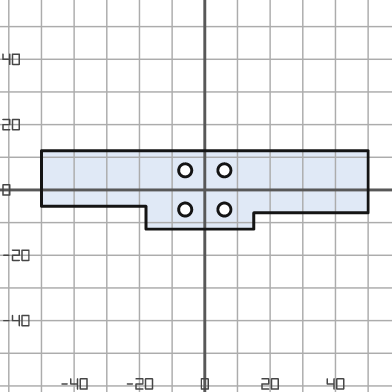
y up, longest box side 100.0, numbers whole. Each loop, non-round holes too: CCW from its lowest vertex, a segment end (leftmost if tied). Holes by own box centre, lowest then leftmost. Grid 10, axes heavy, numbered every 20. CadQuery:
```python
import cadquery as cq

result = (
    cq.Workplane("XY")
    .moveTo(-18.0, -12.0)
    .lineTo(15.0, -12.0)
    .lineTo(15.0, -7.0)
    .lineTo(50.0, -7.0)
    .lineTo(50.0, 12.0)
    .lineTo(-50.0, 12.0)
    .lineTo(-50.0, -5.0)
    .lineTo(-18.0, -5.0)
    .close()
    .moveTo(-6.0, -6.0)
    .circle(2.0)
    .moveTo(6.0, -6.0)
    .circle(2.0)
    .moveTo(-6.0, 6.0)
    .circle(2.0)
    .moveTo(6.0, 6.0)
    .circle(2.0)
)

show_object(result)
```